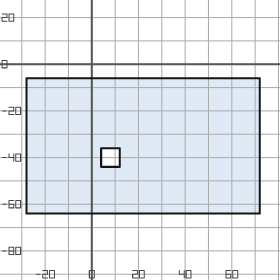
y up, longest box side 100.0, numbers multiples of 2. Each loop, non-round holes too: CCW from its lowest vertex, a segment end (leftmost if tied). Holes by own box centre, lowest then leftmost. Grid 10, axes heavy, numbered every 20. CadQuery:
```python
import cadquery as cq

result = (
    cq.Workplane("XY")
    .moveTo(-28.0, -64.0)
    .lineTo(72.0, -64.0)
    .lineTo(72.0, -6.0)
    .lineTo(-28.0, -6.0)
    .close()
    .moveTo(4.0, -44.0)
    .lineTo(12.0, -44.0)
    .lineTo(12.0, -36.0)
    .lineTo(4.0, -36.0)
    .close()
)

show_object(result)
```